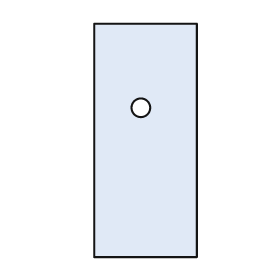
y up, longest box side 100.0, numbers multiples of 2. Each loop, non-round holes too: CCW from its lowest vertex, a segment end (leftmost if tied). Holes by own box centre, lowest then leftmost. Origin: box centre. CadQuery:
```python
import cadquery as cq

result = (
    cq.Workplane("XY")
    .moveTo(-22.0, -50.0)
    .lineTo(22.0, -50.0)
    .lineTo(22.0, 50.0)
    .lineTo(-22.0, 50.0)
    .close()
    .moveTo(-2.0, 14.0)
    .circle(4.0)
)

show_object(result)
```